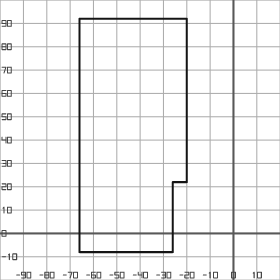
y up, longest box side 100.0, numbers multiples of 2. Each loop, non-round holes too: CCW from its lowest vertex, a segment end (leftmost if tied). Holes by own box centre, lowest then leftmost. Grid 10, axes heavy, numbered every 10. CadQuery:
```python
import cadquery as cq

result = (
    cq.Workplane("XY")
    .moveTo(-66.0, -8.0)
    .lineTo(-26.0, -8.0)
    .lineTo(-26.0, 22.0)
    .lineTo(-20.0, 22.0)
    .lineTo(-20.0, 92.0)
    .lineTo(-66.0, 92.0)
    .close()
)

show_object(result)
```